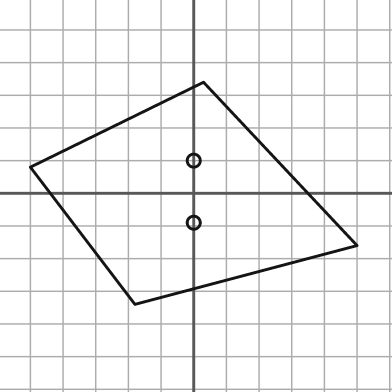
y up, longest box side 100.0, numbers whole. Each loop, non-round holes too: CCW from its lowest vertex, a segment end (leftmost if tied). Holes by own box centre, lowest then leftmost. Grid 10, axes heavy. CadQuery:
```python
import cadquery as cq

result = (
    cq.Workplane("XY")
    .moveTo(-18.0, -34.0)
    .lineTo(50.0, -16.0)
    .lineTo(3.0, 34.0)
    .lineTo(-50.0, 8.0)
    .close()
    .moveTo(0.0, -9.0)
    .circle(2.0)
    .moveTo(0.0, 10.0)
    .circle(2.0)
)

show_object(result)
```